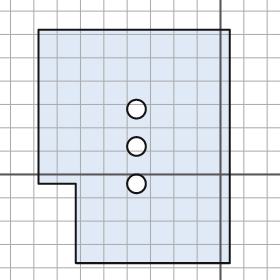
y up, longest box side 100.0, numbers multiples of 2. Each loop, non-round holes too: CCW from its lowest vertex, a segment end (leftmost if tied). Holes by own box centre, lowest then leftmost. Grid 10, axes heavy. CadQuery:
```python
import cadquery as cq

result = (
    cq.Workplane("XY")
    .moveTo(-62.0, -38.0)
    .lineTo(4.0, -38.0)
    .lineTo(4.0, 62.0)
    .lineTo(-78.0, 62.0)
    .lineTo(-78.0, -4.0)
    .lineTo(-62.0, -4.0)
    .close()
    .moveTo(-36.0, -4.0)
    .circle(4.0)
    .moveTo(-36.0, 12.0)
    .circle(4.0)
    .moveTo(-36.0, 28.0)
    .circle(4.0)
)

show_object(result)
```